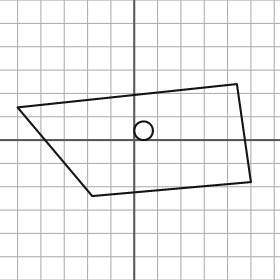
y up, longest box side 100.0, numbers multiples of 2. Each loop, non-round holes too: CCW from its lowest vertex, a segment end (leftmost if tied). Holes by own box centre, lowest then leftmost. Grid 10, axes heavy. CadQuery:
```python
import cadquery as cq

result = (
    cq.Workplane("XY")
    .moveTo(-18.0, -24.0)
    .lineTo(50.0, -18.0)
    .lineTo(44.0, 24.0)
    .lineTo(-50.0, 14.0)
    .close()
    .moveTo(4.0, 4.0)
    .circle(4.0)
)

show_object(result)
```